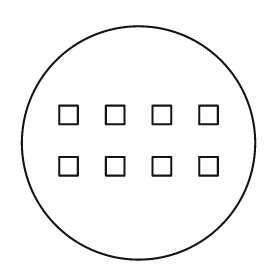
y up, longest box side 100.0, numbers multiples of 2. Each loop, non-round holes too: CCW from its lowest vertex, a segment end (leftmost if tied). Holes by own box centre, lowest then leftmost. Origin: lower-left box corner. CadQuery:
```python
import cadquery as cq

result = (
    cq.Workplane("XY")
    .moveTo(50.0, 50.0)
    .circle(50.0)
    .moveTo(16.0, 36.0)
    .lineTo(24.0, 36.0)
    .lineTo(24.0, 44.0)
    .lineTo(16.0, 44.0)
    .close()
    .moveTo(36.0, 36.0)
    .lineTo(44.0, 36.0)
    .lineTo(44.0, 44.0)
    .lineTo(36.0, 44.0)
    .close()
    .moveTo(56.0, 36.0)
    .lineTo(64.0, 36.0)
    .lineTo(64.0, 44.0)
    .lineTo(56.0, 44.0)
    .close()
    .moveTo(76.0, 36.0)
    .lineTo(84.0, 36.0)
    .lineTo(84.0, 44.0)
    .lineTo(76.0, 44.0)
    .close()
    .moveTo(16.0, 58.0)
    .lineTo(24.0, 58.0)
    .lineTo(24.0, 66.0)
    .lineTo(16.0, 66.0)
    .close()
    .moveTo(36.0, 58.0)
    .lineTo(44.0, 58.0)
    .lineTo(44.0, 66.0)
    .lineTo(36.0, 66.0)
    .close()
    .moveTo(56.0, 58.0)
    .lineTo(64.0, 58.0)
    .lineTo(64.0, 66.0)
    .lineTo(56.0, 66.0)
    .close()
    .moveTo(76.0, 58.0)
    .lineTo(84.0, 58.0)
    .lineTo(84.0, 66.0)
    .lineTo(76.0, 66.0)
    .close()
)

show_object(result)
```